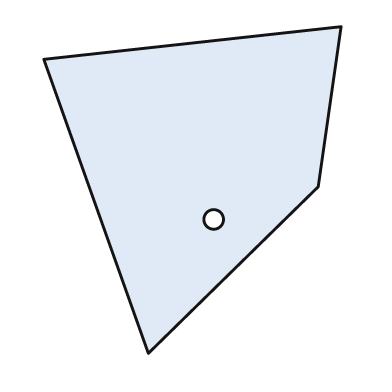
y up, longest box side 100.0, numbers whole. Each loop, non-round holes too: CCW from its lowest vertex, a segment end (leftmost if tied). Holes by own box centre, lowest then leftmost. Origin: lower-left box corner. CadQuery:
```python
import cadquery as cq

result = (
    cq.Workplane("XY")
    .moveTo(32.0, 0.0)
    .lineTo(84.0, 51.0)
    .lineTo(91.0, 100.0)
    .lineTo(0.0, 90.0)
    .close()
    .moveTo(52.0, 41.0)
    .circle(3.0)
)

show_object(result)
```